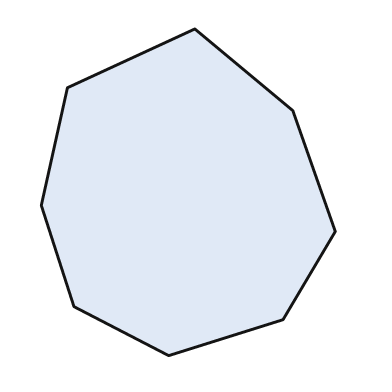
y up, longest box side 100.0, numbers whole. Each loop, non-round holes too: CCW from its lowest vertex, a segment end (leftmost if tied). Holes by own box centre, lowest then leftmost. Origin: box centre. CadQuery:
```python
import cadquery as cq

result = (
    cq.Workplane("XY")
    .moveTo(-6.0, -50.0)
    .lineTo(29.0, -39.0)
    .lineTo(45.0, -12.0)
    .lineTo(32.0, 25.0)
    .lineTo(2.0, 50.0)
    .lineTo(-37.0, 32.0)
    .lineTo(-45.0, -4.0)
    .lineTo(-35.0, -35.0)
    .close()
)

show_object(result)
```